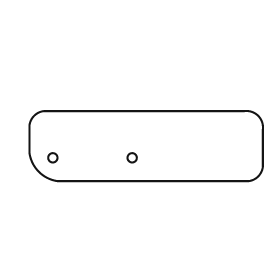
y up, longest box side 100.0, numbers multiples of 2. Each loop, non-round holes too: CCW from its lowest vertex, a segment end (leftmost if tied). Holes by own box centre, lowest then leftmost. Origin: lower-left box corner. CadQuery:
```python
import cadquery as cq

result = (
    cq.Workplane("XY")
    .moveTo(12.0, 0.0)
    .lineTo(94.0, 0.0)
    .threePointArc((98.0, 2.0), (100.0, 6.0))
    .lineTo(100.0, 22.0)
    .threePointArc((98.0, 28.0), (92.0, 30.0))
    .lineTo(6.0, 30.0)
    .threePointArc((2.0, 28.0), (0.0, 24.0))
    .lineTo(0.0, 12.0)
    .threePointArc((4.0, 4.0), (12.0, 0.0))
    .close()
    .moveTo(10.0, 10.0)
    .circle(2.0)
    .moveTo(44.0, 10.0)
    .circle(2.0)
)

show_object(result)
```